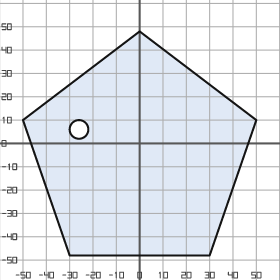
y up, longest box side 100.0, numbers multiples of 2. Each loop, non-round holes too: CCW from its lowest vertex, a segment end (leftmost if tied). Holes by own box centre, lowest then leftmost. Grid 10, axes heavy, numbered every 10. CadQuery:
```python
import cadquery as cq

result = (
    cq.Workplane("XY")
    .moveTo(-30.0, -48.0)
    .lineTo(30.0, -48.0)
    .lineTo(50.0, 10.0)
    .lineTo(0.0, 48.0)
    .lineTo(-50.0, 10.0)
    .close()
    .moveTo(-26.0, 6.0)
    .circle(4.0)
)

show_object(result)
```